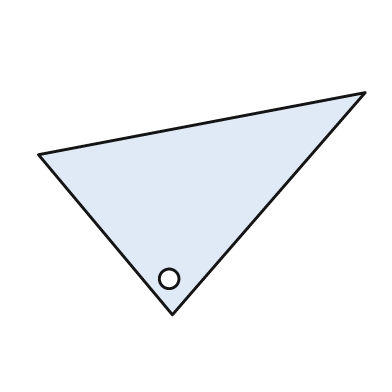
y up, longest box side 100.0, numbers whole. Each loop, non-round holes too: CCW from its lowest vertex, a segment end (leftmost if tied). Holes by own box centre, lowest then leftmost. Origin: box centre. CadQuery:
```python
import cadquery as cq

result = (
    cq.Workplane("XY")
    .moveTo(-9.0, -34.0)
    .lineTo(50.0, 34.0)
    .lineTo(-50.0, 15.0)
    .close()
    .moveTo(-10.0, -23.0)
    .circle(3.0)
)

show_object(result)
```